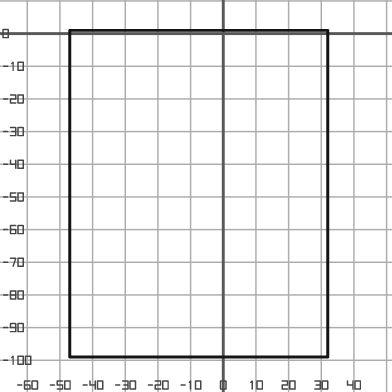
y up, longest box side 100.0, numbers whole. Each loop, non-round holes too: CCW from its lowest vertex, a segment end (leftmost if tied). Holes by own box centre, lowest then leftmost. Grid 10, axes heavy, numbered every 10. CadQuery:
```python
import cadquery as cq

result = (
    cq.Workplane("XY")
    .moveTo(-47.0, -99.0)
    .lineTo(32.0, -99.0)
    .lineTo(32.0, 1.0)
    .lineTo(-47.0, 1.0)
    .close()
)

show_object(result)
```